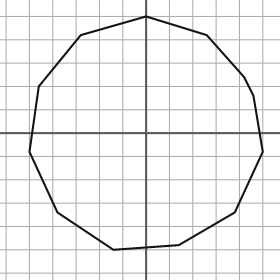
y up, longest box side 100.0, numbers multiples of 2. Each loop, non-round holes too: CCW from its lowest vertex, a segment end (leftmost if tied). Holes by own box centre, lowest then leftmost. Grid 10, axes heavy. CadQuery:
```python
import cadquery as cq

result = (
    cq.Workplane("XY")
    .moveTo(-14.0, -50.0)
    .lineTo(14.0, -48.0)
    .lineTo(38.0, -34.0)
    .lineTo(50.0, -8.0)
    .lineTo(46.0, 16.0)
    .lineTo(42.0, 24.0)
    .lineTo(26.0, 42.0)
    .lineTo(0.0, 50.0)
    .lineTo(-28.0, 42.0)
    .lineTo(-46.0, 20.0)
    .lineTo(-50.0, -8.0)
    .lineTo(-38.0, -34.0)
    .close()
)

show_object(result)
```